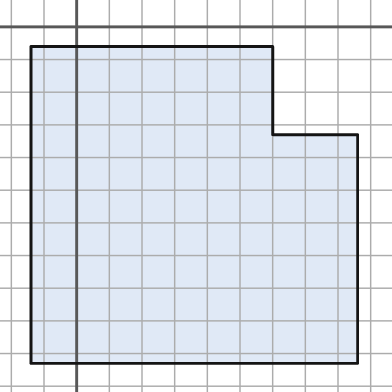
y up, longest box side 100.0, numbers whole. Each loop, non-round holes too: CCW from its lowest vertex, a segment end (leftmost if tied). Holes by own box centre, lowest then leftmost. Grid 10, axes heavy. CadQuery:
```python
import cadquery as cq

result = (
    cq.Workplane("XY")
    .moveTo(-14.0, -103.0)
    .lineTo(86.0, -103.0)
    .lineTo(86.0, -33.0)
    .lineTo(60.0, -33.0)
    .lineTo(60.0, -6.0)
    .lineTo(-14.0, -6.0)
    .close()
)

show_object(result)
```